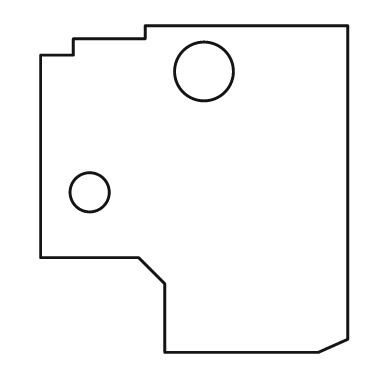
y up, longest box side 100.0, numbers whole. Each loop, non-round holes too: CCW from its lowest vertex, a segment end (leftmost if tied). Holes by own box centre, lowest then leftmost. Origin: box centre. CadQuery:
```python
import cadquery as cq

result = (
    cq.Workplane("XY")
    .moveTo(-9.0, -50.0)
    .lineTo(38.0, -50.0)
    .lineTo(47.0, -46.0)
    .lineTo(47.0, 50.0)
    .lineTo(-15.0, 50.0)
    .lineTo(-15.0, 46.0)
    .lineTo(-37.0, 46.0)
    .lineTo(-37.0, 41.0)
    .lineTo(-47.0, 41.0)
    .lineTo(-47.0, -21.0)
    .lineTo(-17.0, -21.0)
    .lineTo(-9.0, -29.0)
    .close()
    .moveTo(-32.0, -1.0)
    .circle(6.0)
    .moveTo(3.0, 36.0)
    .circle(9.0)
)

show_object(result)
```